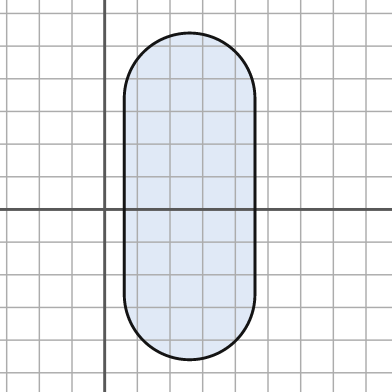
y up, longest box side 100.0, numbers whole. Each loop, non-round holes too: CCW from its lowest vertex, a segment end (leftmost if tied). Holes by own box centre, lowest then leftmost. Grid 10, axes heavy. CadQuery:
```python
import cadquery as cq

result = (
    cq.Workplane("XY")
    .moveTo(6.0, -26.0)
    .threePointArc((26.0, -46.0), (46.0, -26.0))
    .lineTo(46.0, 34.0)
    .threePointArc((26.0, 54.0), (6.0, 34.0))
    .close()
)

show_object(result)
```